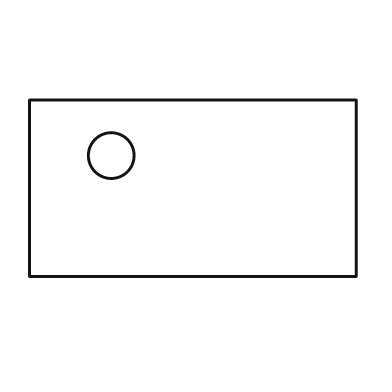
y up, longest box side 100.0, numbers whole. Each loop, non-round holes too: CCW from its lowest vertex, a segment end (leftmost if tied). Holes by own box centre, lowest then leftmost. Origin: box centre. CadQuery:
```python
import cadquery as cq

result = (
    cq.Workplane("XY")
    .moveTo(-50.0, -27.0)
    .lineTo(50.0, -27.0)
    .lineTo(50.0, 27.0)
    .lineTo(-50.0, 27.0)
    .close()
    .moveTo(-25.0, 10.0)
    .circle(7.0)
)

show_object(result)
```